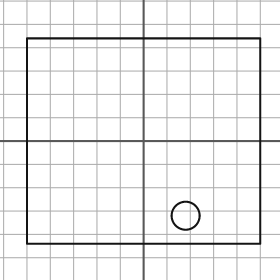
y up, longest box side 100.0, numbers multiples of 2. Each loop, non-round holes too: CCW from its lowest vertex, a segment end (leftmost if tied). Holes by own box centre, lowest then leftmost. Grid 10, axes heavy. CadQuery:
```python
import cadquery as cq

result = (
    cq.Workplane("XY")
    .moveTo(-50.0, -44.0)
    .lineTo(50.0, -44.0)
    .lineTo(50.0, 44.0)
    .lineTo(-50.0, 44.0)
    .close()
    .moveTo(18.0, -32.0)
    .circle(6.0)
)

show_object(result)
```